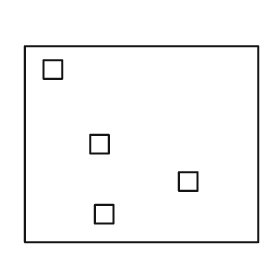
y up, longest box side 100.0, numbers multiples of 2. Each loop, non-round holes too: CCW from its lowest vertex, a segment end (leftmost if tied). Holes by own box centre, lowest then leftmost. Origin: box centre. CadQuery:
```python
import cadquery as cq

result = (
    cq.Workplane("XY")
    .moveTo(-50.0, -42.0)
    .lineTo(50.0, -42.0)
    .lineTo(50.0, 42.0)
    .lineTo(-50.0, 42.0)
    .close()
    .moveTo(-20.0, -34.0)
    .lineTo(-12.0, -34.0)
    .lineTo(-12.0, -26.0)
    .lineTo(-20.0, -26.0)
    .close()
    .moveTo(16.0, -20.0)
    .lineTo(24.0, -20.0)
    .lineTo(24.0, -12.0)
    .lineTo(16.0, -12.0)
    .close()
    .moveTo(-22.0, -4.0)
    .lineTo(-14.0, -4.0)
    .lineTo(-14.0, 4.0)
    .lineTo(-22.0, 4.0)
    .close()
    .moveTo(-42.0, 28.0)
    .lineTo(-34.0, 28.0)
    .lineTo(-34.0, 36.0)
    .lineTo(-42.0, 36.0)
    .close()
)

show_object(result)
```